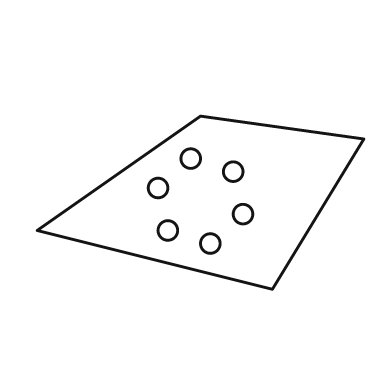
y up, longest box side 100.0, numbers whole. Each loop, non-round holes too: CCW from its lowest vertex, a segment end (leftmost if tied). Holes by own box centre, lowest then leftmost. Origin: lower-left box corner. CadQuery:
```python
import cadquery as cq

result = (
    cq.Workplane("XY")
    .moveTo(72.0, 0.0)
    .lineTo(100.0, 46.0)
    .lineTo(50.0, 53.0)
    .lineTo(0.0, 18.0)
    .close()
    .moveTo(53.0, 14.0)
    .circle(3.0)
    .moveTo(40.0, 18.0)
    .circle(3.0)
    .moveTo(63.0, 23.0)
    .circle(3.0)
    .moveTo(37.0, 31.0)
    .circle(3.0)
    .moveTo(60.0, 36.0)
    .circle(3.0)
    .moveTo(47.0, 40.0)
    .circle(3.0)
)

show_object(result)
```